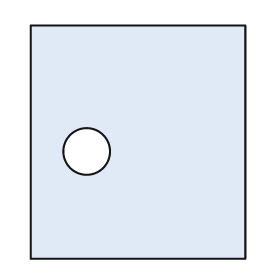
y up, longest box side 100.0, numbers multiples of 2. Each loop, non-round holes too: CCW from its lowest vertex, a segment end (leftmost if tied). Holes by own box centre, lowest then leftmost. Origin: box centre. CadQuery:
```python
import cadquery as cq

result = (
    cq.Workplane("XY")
    .moveTo(-46.0, -50.0)
    .lineTo(46.0, -50.0)
    .lineTo(46.0, 50.0)
    .lineTo(-46.0, 50.0)
    .close()
    .moveTo(-22.0, -4.0)
    .circle(10.0)
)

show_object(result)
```